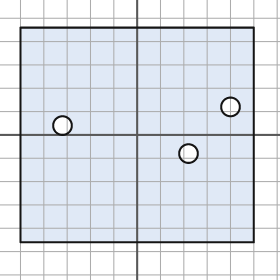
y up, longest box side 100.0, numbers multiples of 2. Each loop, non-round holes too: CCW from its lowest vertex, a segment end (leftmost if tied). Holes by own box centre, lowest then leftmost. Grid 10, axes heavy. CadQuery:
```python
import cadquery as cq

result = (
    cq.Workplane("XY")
    .moveTo(-50.0, -46.0)
    .lineTo(50.0, -46.0)
    .lineTo(50.0, 46.0)
    .lineTo(-50.0, 46.0)
    .close()
    .moveTo(22.0, -8.0)
    .circle(4.0)
    .moveTo(-32.0, 4.0)
    .circle(4.0)
    .moveTo(40.0, 12.0)
    .circle(4.0)
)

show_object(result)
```